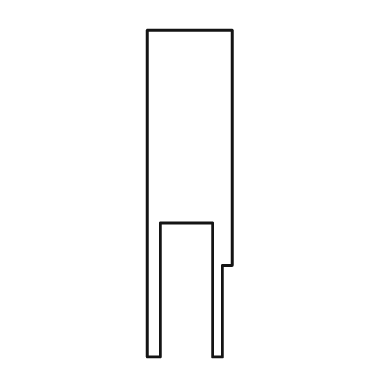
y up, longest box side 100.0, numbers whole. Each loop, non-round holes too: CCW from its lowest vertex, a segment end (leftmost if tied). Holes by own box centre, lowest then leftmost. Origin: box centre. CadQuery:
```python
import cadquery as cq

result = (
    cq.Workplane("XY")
    .moveTo(-13.0, -50.0)
    .lineTo(-9.0, -50.0)
    .lineTo(-9.0, -9.0)
    .lineTo(7.0, -9.0)
    .lineTo(7.0, -50.0)
    .lineTo(10.0, -50.0)
    .lineTo(10.0, -22.0)
    .lineTo(13.0, -22.0)
    .lineTo(13.0, 50.0)
    .lineTo(-13.0, 50.0)
    .close()
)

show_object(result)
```